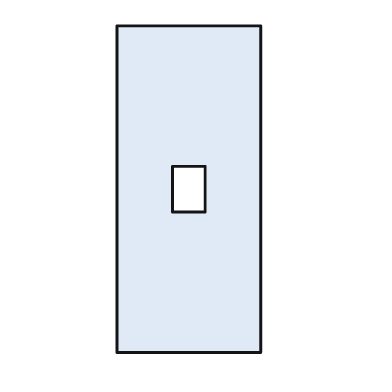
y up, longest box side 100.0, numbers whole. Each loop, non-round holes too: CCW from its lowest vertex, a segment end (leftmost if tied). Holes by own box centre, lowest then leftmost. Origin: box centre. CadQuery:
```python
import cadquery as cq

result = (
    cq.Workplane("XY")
    .moveTo(-22.0, -50.0)
    .lineTo(22.0, -50.0)
    .lineTo(22.0, 50.0)
    .lineTo(-22.0, 50.0)
    .close()
    .moveTo(-5.0, -7.0)
    .lineTo(5.0, -7.0)
    .lineTo(5.0, 7.0)
    .lineTo(-5.0, 7.0)
    .close()
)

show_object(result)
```